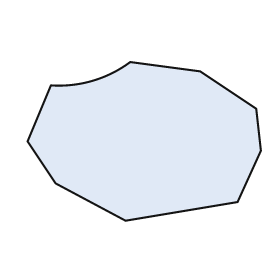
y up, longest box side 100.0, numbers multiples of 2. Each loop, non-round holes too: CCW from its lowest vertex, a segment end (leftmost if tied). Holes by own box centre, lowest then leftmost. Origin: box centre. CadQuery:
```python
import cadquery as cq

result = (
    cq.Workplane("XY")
    .moveTo(-8.0, -34.0)
    .lineTo(40.0, -26.0)
    .lineTo(50.0, -4.0)
    .lineTo(48.0, 14.0)
    .lineTo(24.0, 30.0)
    .lineTo(-6.0, 34.0)
    .threePointArc((-22.0, 26.0), (-40.0, 24.0))
    .lineTo(-50.0, 0.0)
    .lineTo(-38.0, -18.0)
    .close()
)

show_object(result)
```